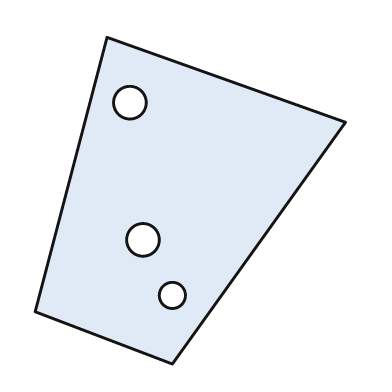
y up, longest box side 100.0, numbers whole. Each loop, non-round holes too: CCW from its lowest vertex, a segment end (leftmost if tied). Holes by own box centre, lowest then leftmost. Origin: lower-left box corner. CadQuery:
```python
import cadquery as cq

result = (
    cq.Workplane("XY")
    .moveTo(42.0, 0.0)
    .lineTo(95.0, 74.0)
    .lineTo(22.0, 100.0)
    .lineTo(0.0, 16.0)
    .close()
    .moveTo(42.0, 21.0)
    .circle(4.0)
    .moveTo(33.0, 38.0)
    .circle(5.0)
    .moveTo(29.0, 80.0)
    .circle(5.0)
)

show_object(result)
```